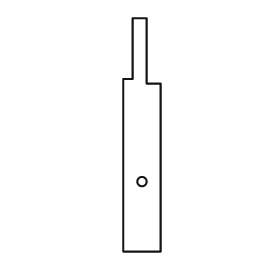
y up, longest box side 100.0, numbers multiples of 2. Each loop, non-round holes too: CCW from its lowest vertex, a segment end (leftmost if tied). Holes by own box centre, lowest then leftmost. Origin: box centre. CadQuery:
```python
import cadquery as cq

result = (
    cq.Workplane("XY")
    .moveTo(-8.0, -50.0)
    .lineTo(8.0, -50.0)
    .lineTo(8.0, 22.0)
    .lineTo(2.0, 22.0)
    .lineTo(2.0, 50.0)
    .lineTo(-4.0, 50.0)
    .lineTo(-4.0, 24.0)
    .lineTo(-8.0, 24.0)
    .close()
    .moveTo(0.0, -20.0)
    .circle(2.0)
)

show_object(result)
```